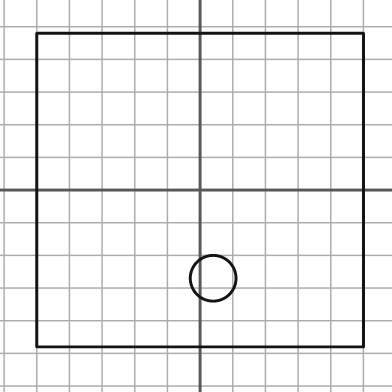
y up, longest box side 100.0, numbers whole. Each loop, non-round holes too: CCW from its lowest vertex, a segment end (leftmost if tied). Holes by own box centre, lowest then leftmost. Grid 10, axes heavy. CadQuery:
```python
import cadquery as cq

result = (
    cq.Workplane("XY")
    .moveTo(-50.0, -48.0)
    .lineTo(50.0, -48.0)
    .lineTo(50.0, 48.0)
    .lineTo(-50.0, 48.0)
    .close()
    .moveTo(4.0, -27.0)
    .circle(7.0)
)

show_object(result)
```